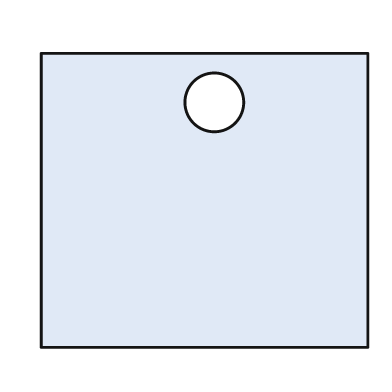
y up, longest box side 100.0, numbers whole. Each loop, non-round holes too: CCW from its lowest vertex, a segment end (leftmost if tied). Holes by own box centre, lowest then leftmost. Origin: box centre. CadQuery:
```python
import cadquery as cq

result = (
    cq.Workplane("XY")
    .moveTo(-50.0, -45.0)
    .lineTo(50.0, -45.0)
    .lineTo(50.0, 45.0)
    .lineTo(-50.0, 45.0)
    .close()
    .moveTo(3.0, 30.0)
    .circle(9.0)
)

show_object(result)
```